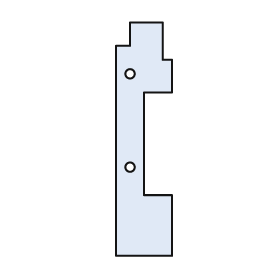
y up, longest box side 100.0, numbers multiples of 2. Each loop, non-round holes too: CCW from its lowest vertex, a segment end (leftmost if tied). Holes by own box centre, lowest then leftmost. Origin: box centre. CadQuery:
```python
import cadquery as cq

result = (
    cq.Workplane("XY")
    .moveTo(-12.0, -50.0)
    .lineTo(12.0, -50.0)
    .lineTo(12.0, -24.0)
    .lineTo(0.0, -24.0)
    .lineTo(0.0, 20.0)
    .lineTo(12.0, 20.0)
    .lineTo(12.0, 34.0)
    .lineTo(8.0, 34.0)
    .lineTo(8.0, 50.0)
    .lineTo(-6.0, 50.0)
    .lineTo(-6.0, 40.0)
    .lineTo(-12.0, 40.0)
    .close()
    .moveTo(-6.0, -12.0)
    .circle(2.0)
    .moveTo(-6.0, 28.0)
    .circle(2.0)
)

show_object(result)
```